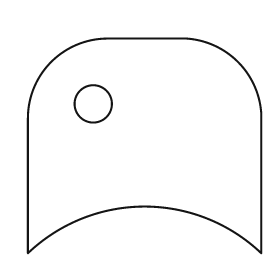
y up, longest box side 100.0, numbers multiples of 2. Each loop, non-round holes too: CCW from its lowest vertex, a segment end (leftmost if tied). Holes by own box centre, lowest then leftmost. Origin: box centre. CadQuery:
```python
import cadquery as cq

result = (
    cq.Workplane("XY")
    .moveTo(-50.0, -46.0)
    .threePointArc((0.0, -26.0), (50.0, -46.0))
    .lineTo(50.0, 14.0)
    .threePointArc((40.0, 36.0), (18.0, 46.0))
    .lineTo(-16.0, 46.0)
    .threePointArc((-40.0, 36.0), (-50.0, 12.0))
    .close()
    .moveTo(-22.0, 18.0)
    .circle(8.0)
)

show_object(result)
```